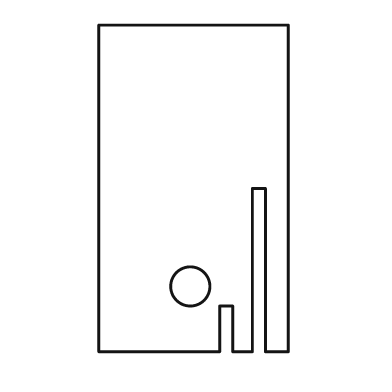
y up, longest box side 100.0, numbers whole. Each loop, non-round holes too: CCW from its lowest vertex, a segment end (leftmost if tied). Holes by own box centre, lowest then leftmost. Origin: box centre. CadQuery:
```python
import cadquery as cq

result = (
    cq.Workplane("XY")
    .moveTo(-29.0, -50.0)
    .lineTo(8.0, -50.0)
    .lineTo(8.0, -36.0)
    .lineTo(12.0, -36.0)
    .lineTo(12.0, -50.0)
    .lineTo(18.0, -50.0)
    .lineTo(18.0, 0.0)
    .lineTo(22.0, 0.0)
    .lineTo(22.0, -50.0)
    .lineTo(29.0, -50.0)
    .lineTo(29.0, 50.0)
    .lineTo(-29.0, 50.0)
    .close()
    .moveTo(-1.0, -30.0)
    .circle(6.0)
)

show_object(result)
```